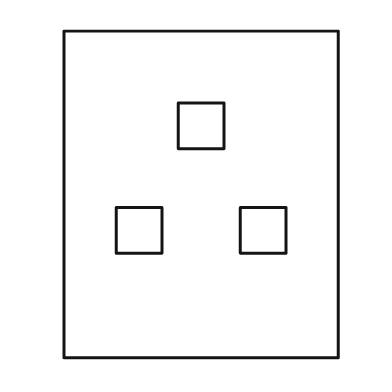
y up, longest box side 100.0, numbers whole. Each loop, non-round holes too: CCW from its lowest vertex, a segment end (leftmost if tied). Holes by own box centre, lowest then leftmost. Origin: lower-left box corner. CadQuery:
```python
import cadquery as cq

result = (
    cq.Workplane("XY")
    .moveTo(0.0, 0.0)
    .lineTo(84.0, 0.0)
    .lineTo(84.0, 100.0)
    .lineTo(0.0, 100.0)
    .close()
    .moveTo(16.0, 32.0)
    .lineTo(30.0, 32.0)
    .lineTo(30.0, 46.0)
    .lineTo(16.0, 46.0)
    .close()
    .moveTo(54.0, 32.0)
    .lineTo(68.0, 32.0)
    .lineTo(68.0, 46.0)
    .lineTo(54.0, 46.0)
    .close()
    .moveTo(35.0, 64.0)
    .lineTo(49.0, 64.0)
    .lineTo(49.0, 78.0)
    .lineTo(35.0, 78.0)
    .close()
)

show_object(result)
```